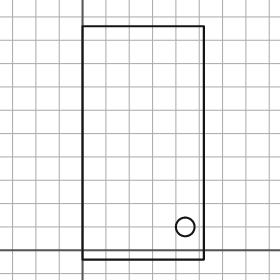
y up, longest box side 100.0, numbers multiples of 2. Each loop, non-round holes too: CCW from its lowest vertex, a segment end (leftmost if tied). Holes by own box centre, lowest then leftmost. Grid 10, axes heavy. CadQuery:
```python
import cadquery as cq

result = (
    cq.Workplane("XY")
    .moveTo(0.0, -4.0)
    .lineTo(52.0, -4.0)
    .lineTo(52.0, 96.0)
    .lineTo(0.0, 96.0)
    .close()
    .moveTo(44.0, 10.0)
    .circle(4.0)
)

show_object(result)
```